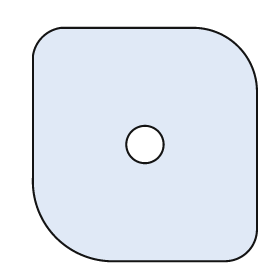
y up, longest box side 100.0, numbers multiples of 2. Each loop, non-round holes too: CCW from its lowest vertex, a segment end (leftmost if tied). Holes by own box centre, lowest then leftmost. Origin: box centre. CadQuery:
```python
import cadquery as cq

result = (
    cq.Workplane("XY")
    .moveTo(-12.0, -50.0)
    .lineTo(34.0, -50.0)
    .threePointArc((44.0, -46.0), (48.0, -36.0))
    .lineTo(48.0, 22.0)
    .threePointArc((40.0, 42.0), (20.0, 50.0))
    .lineTo(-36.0, 50.0)
    .threePointArc((-44.0, 46.0), (-48.0, 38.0))
    .lineTo(-48.0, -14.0)
    .threePointArc((-38.0, -40.0), (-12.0, -50.0))
    .close()
    .moveTo(0.0, 0.0)
    .circle(8.0)
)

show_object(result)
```